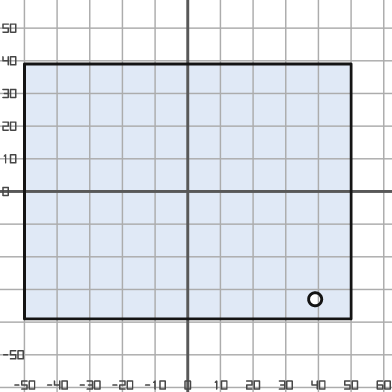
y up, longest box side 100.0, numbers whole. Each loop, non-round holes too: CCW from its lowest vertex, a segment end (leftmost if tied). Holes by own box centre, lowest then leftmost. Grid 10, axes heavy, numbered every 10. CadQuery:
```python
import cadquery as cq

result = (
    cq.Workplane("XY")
    .moveTo(-50.0, -39.0)
    .lineTo(50.0, -39.0)
    .lineTo(50.0, 39.0)
    .lineTo(-50.0, 39.0)
    .close()
    .moveTo(39.0, -33.0)
    .circle(2.0)
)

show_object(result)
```